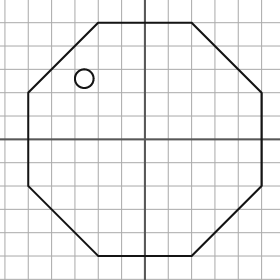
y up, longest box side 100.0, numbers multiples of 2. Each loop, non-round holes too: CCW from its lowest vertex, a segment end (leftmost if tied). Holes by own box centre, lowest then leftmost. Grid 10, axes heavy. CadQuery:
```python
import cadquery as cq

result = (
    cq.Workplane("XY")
    .moveTo(-20.0, -50.0)
    .lineTo(20.0, -50.0)
    .lineTo(50.0, -20.0)
    .lineTo(50.0, 20.0)
    .lineTo(20.0, 50.0)
    .lineTo(-20.0, 50.0)
    .lineTo(-50.0, 20.0)
    .lineTo(-50.0, -20.0)
    .close()
    .moveTo(-26.0, 26.0)
    .circle(4.0)
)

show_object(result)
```